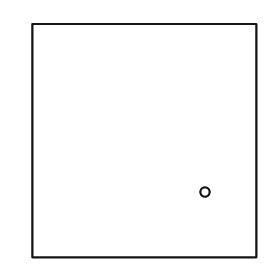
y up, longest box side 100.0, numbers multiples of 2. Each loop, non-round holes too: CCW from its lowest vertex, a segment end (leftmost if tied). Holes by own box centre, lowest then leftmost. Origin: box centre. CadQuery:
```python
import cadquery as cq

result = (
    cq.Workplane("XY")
    .moveTo(-48.0, -50.0)
    .lineTo(48.0, -50.0)
    .lineTo(48.0, 50.0)
    .lineTo(-48.0, 50.0)
    .close()
    .moveTo(26.0, -22.0)
    .circle(2.0)
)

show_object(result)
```